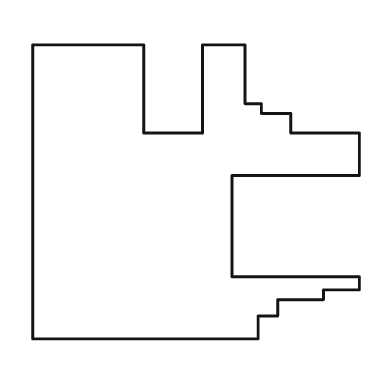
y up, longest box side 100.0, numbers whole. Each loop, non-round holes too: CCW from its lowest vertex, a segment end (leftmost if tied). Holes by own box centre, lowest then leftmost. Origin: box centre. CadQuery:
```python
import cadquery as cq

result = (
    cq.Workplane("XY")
    .moveTo(-50.0, -45.0)
    .lineTo(19.0, -45.0)
    .lineTo(19.0, -38.0)
    .lineTo(25.0, -38.0)
    .lineTo(25.0, -33.0)
    .lineTo(39.0, -33.0)
    .lineTo(39.0, -30.0)
    .lineTo(50.0, -30.0)
    .lineTo(50.0, -26.0)
    .lineTo(11.0, -26.0)
    .lineTo(11.0, 5.0)
    .lineTo(50.0, 5.0)
    .lineTo(50.0, 18.0)
    .lineTo(29.0, 18.0)
    .lineTo(29.0, 24.0)
    .lineTo(20.0, 24.0)
    .lineTo(20.0, 27.0)
    .lineTo(15.0, 27.0)
    .lineTo(15.0, 45.0)
    .lineTo(2.0, 45.0)
    .lineTo(2.0, 18.0)
    .lineTo(-16.0, 18.0)
    .lineTo(-16.0, 45.0)
    .lineTo(-50.0, 45.0)
    .close()
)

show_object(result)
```